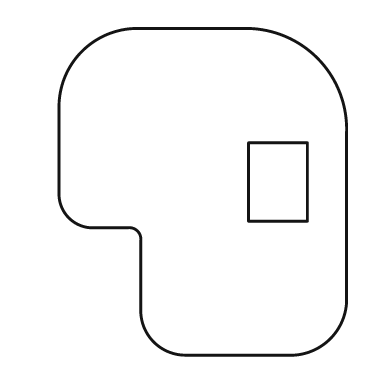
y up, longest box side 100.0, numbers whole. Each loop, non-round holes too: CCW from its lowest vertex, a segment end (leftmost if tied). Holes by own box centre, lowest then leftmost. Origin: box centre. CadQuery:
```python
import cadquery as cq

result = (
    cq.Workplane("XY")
    .moveTo(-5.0, -50.0)
    .lineTo(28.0, -50.0)
    .threePointArc((39.0, -45.0), (44.0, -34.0))
    .lineTo(44.0, 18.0)
    .threePointArc((35.0, 41.0), (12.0, 50.0))
    .lineTo(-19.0, 50.0)
    .threePointArc((-37.0, 43.0), (-44.0, 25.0))
    .lineTo(-44.0, 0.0)
    .threePointArc((-41.0, -8.0), (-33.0, -11.0))
    .lineTo(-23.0, -11.0)
    .threePointArc((-20.0, -12.0), (-19.0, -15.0))
    .lineTo(-19.0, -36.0)
    .threePointArc((-15.0, -46.0), (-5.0, -50.0))
    .close()
    .moveTo(14.0, -9.0)
    .lineTo(32.0, -9.0)
    .lineTo(32.0, 15.0)
    .lineTo(14.0, 15.0)
    .close()
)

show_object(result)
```